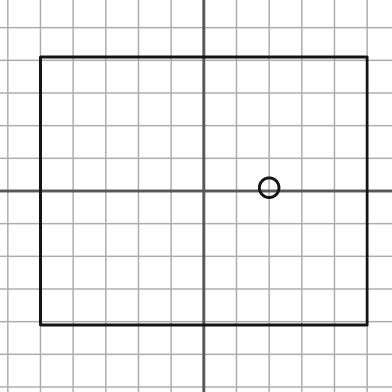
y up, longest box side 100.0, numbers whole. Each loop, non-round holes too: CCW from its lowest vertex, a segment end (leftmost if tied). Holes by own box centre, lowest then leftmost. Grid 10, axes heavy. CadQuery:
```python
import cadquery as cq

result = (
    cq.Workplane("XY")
    .moveTo(-50.0, -41.0)
    .lineTo(50.0, -41.0)
    .lineTo(50.0, 41.0)
    .lineTo(-50.0, 41.0)
    .close()
    .moveTo(20.0, 1.0)
    .circle(3.0)
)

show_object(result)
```